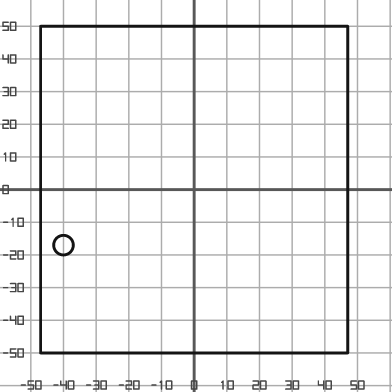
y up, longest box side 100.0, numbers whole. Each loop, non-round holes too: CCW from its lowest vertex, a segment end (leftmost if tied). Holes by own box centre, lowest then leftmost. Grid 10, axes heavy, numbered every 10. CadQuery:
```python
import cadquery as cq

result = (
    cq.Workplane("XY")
    .moveTo(-47.0, -50.0)
    .lineTo(47.0, -50.0)
    .lineTo(47.0, 50.0)
    .lineTo(-47.0, 50.0)
    .close()
    .moveTo(-40.0, -17.0)
    .circle(3.0)
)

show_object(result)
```